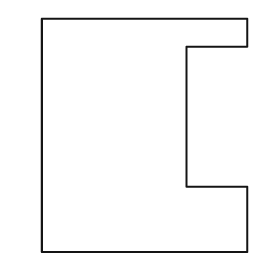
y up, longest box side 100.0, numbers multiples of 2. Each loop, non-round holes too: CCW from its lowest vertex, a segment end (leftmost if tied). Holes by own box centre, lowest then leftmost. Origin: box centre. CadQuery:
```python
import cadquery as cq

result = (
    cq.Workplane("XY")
    .moveTo(-44.0, -50.0)
    .lineTo(44.0, -50.0)
    .lineTo(44.0, -22.0)
    .lineTo(18.0, -22.0)
    .lineTo(18.0, 38.0)
    .lineTo(44.0, 38.0)
    .lineTo(44.0, 50.0)
    .lineTo(-44.0, 50.0)
    .close()
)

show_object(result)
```